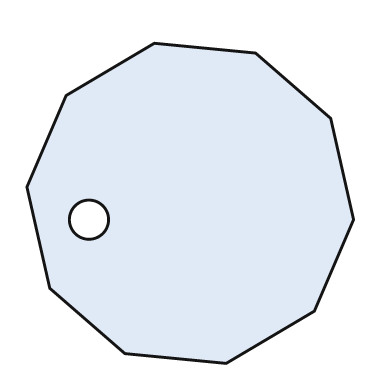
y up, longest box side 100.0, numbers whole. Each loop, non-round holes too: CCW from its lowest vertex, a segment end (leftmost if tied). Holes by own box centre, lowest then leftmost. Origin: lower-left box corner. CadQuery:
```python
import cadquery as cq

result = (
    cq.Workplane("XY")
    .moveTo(61.0, 0.0)
    .lineTo(88.0, 16.0)
    .lineTo(100.0, 44.0)
    .lineTo(93.0, 75.0)
    .lineTo(70.0, 95.0)
    .lineTo(39.0, 98.0)
    .lineTo(12.0, 82.0)
    .lineTo(0.0, 54.0)
    .lineTo(7.0, 23.0)
    .lineTo(30.0, 3.0)
    .close()
    .moveTo(19.0, 44.0)
    .circle(6.0)
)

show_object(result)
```